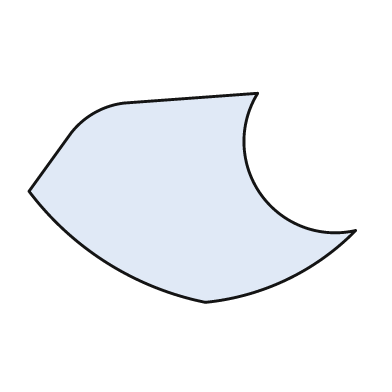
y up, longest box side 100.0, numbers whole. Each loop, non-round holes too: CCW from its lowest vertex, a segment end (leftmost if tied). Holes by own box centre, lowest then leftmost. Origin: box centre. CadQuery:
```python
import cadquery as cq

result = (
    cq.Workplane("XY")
    .moveTo(4.0, -32.0)
    .threePointArc((29.0, -25.0), (50.0, -10.0))
    .threePointArc((21.0, 1.0), (20.0, 32.0))
    .lineTo(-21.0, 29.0)
    .threePointArc((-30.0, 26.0), (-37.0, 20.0))
    .lineTo(-50.0, 2.0)
    .threePointArc((-26.0, -20.0), (4.0, -32.0))
    .close()
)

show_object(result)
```